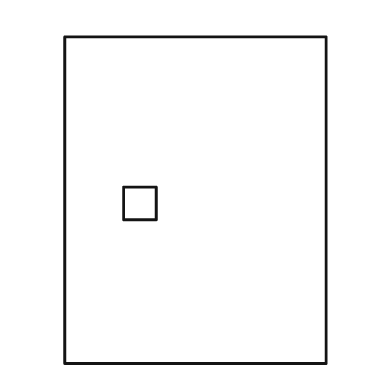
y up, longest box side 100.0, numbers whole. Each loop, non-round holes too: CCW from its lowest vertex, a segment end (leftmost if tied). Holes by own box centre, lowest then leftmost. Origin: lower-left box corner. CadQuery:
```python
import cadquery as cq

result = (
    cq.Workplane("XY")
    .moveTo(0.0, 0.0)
    .lineTo(80.0, 0.0)
    .lineTo(80.0, 100.0)
    .lineTo(0.0, 100.0)
    .close()
    .moveTo(18.0, 44.0)
    .lineTo(28.0, 44.0)
    .lineTo(28.0, 54.0)
    .lineTo(18.0, 54.0)
    .close()
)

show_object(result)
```